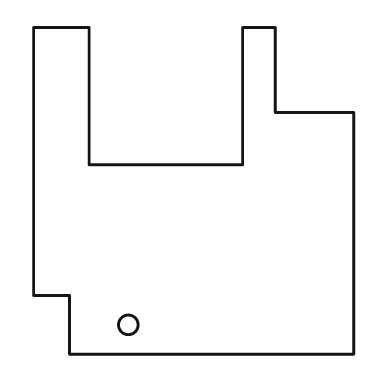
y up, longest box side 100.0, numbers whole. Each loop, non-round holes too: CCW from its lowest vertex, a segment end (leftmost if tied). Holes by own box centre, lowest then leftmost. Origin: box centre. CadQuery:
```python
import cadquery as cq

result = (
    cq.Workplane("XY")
    .moveTo(-38.0, -50.0)
    .lineTo(49.0, -50.0)
    .lineTo(49.0, 24.0)
    .lineTo(25.0, 24.0)
    .lineTo(25.0, 50.0)
    .lineTo(15.0, 50.0)
    .lineTo(15.0, 8.0)
    .lineTo(-32.0, 8.0)
    .lineTo(-32.0, 50.0)
    .lineTo(-49.0, 50.0)
    .lineTo(-49.0, -32.0)
    .lineTo(-38.0, -32.0)
    .close()
    .moveTo(-20.0, -41.0)
    .circle(3.0)
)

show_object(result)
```